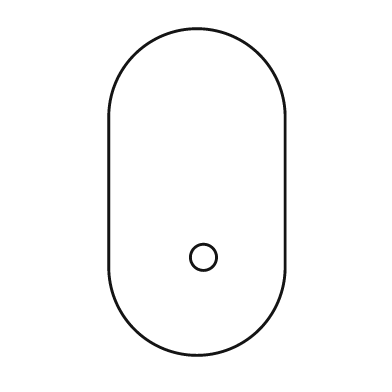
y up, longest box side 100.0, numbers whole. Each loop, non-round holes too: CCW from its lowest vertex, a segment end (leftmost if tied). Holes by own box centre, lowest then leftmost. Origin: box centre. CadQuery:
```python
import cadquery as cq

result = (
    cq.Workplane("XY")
    .moveTo(-27.0, -23.0)
    .threePointArc((0.0, -50.0), (27.0, -23.0))
    .lineTo(27.0, 23.0)
    .threePointArc((0.0, 50.0), (-27.0, 23.0))
    .close()
    .moveTo(2.0, -20.0)
    .circle(4.0)
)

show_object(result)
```